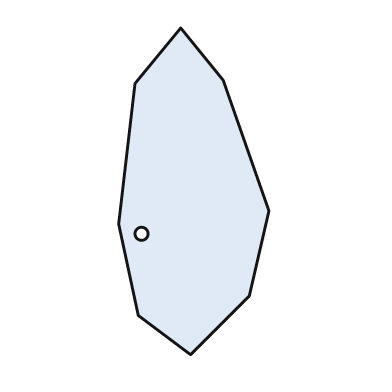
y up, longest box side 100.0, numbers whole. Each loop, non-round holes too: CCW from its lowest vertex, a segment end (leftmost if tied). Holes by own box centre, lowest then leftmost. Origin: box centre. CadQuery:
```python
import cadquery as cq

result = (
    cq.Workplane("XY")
    .moveTo(-1.0, -50.0)
    .lineTo(17.0, -32.0)
    .lineTo(23.0, -6.0)
    .lineTo(9.0, 34.0)
    .lineTo(-4.0, 50.0)
    .lineTo(-18.0, 33.0)
    .lineTo(-23.0, -10.0)
    .lineTo(-17.0, -38.0)
    .close()
    .moveTo(-16.0, -13.0)
    .circle(2.0)
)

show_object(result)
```